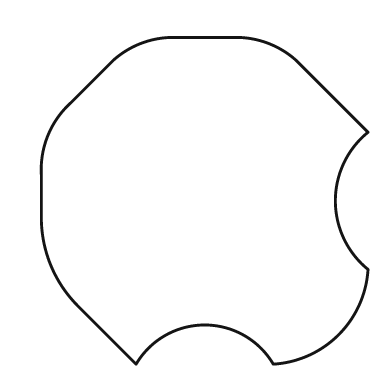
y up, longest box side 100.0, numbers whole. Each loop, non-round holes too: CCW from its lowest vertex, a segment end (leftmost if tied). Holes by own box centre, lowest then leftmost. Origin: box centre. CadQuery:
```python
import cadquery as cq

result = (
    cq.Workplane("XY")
    .moveTo(-21.0, -50.0)
    .threePointArc((0.0, -38.0), (21.0, -50.0))
    .threePointArc((41.0, -41.0), (50.0, -21.0))
    .threePointArc((40.0, 0.0), (50.0, 21.0))
    .lineTo(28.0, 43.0)
    .threePointArc((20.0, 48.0), (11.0, 50.0))
    .lineTo(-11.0, 50.0)
    .threePointArc((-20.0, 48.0), (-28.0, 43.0))
    .lineTo(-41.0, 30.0)
    .threePointArc((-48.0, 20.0), (-50.0, 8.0))
    .lineTo(-50.0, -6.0)
    .threePointArc((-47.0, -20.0), (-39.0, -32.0))
    .close()
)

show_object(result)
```